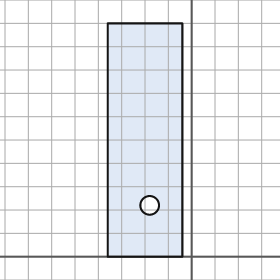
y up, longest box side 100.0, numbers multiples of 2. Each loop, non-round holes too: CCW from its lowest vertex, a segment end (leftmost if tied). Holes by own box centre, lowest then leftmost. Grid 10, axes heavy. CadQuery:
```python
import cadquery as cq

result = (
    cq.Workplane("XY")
    .moveTo(-36.0, 0.0)
    .lineTo(-4.0, 0.0)
    .lineTo(-4.0, 100.0)
    .lineTo(-36.0, 100.0)
    .close()
    .moveTo(-18.0, 22.0)
    .circle(4.0)
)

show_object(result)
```